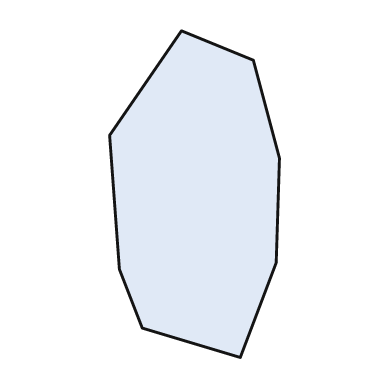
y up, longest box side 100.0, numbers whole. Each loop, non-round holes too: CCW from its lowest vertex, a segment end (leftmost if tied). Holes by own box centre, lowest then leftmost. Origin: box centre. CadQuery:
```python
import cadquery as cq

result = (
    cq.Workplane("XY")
    .moveTo(14.0, -50.0)
    .lineTo(25.0, -21.0)
    .lineTo(26.0, 11.0)
    .lineTo(18.0, 41.0)
    .lineTo(-4.0, 50.0)
    .lineTo(-26.0, 18.0)
    .lineTo(-23.0, -23.0)
    .lineTo(-16.0, -41.0)
    .close()
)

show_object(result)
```